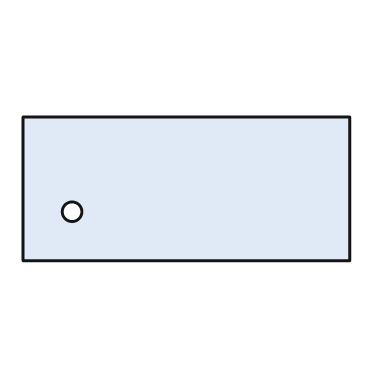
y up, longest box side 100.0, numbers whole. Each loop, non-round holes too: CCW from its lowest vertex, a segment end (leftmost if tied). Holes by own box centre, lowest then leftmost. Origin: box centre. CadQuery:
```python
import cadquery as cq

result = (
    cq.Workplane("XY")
    .moveTo(-50.0, -22.0)
    .lineTo(50.0, -22.0)
    .lineTo(50.0, 22.0)
    .lineTo(-50.0, 22.0)
    .close()
    .moveTo(-35.0, -7.0)
    .circle(3.0)
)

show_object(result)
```